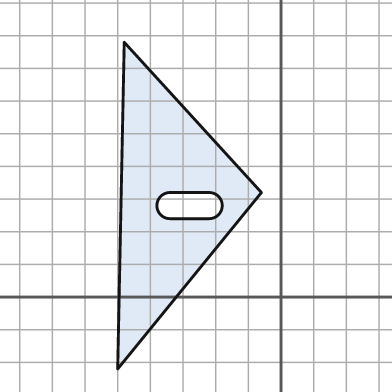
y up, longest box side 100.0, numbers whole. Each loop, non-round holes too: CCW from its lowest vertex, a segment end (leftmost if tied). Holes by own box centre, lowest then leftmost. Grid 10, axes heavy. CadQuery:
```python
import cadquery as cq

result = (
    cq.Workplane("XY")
    .moveTo(-50.0, -22.0)
    .lineTo(-6.0, 32.0)
    .lineTo(-48.0, 78.0)
    .close()
    .moveTo(-34.0, 24.0)
    .lineTo(-22.0, 24.0)
    .threePointArc((-18.0, 28.0), (-22.0, 32.0))
    .lineTo(-34.0, 32.0)
    .threePointArc((-38.0, 28.0), (-34.0, 24.0))
    .close()
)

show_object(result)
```